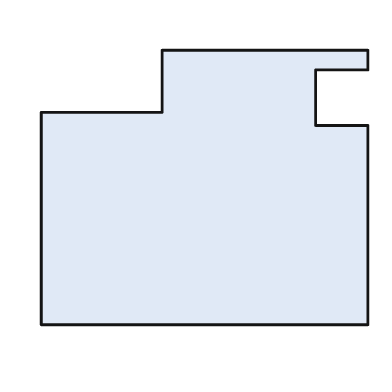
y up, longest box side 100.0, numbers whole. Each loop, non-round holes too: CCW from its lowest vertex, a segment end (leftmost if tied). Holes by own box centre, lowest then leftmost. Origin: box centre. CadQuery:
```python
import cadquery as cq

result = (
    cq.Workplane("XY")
    .moveTo(-50.0, -42.0)
    .lineTo(50.0, -42.0)
    .lineTo(50.0, 19.0)
    .lineTo(34.0, 19.0)
    .lineTo(34.0, 36.0)
    .lineTo(50.0, 36.0)
    .lineTo(50.0, 42.0)
    .lineTo(-13.0, 42.0)
    .lineTo(-13.0, 23.0)
    .lineTo(-50.0, 23.0)
    .close()
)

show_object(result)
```